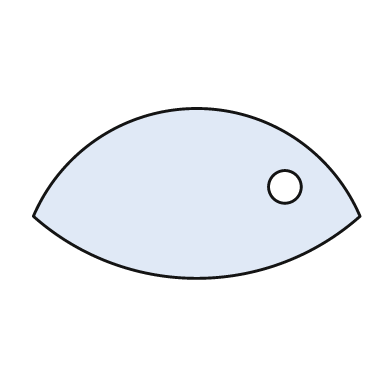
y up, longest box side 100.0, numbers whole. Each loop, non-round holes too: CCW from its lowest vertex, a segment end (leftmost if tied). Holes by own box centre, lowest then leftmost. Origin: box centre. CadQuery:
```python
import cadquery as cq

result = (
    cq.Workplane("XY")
    .moveTo(-50.0, -7.0)
    .threePointArc((0.0, -26.0), (50.0, -7.0))
    .threePointArc((0.0, 26.0), (-50.0, -7.0))
    .close()
    .moveTo(27.0, 2.0)
    .circle(5.0)
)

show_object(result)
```